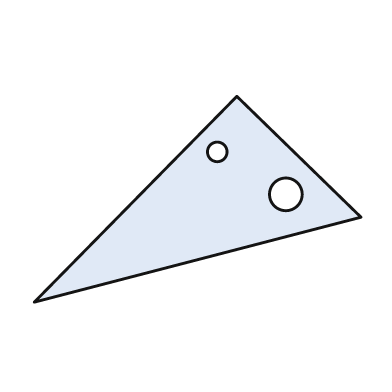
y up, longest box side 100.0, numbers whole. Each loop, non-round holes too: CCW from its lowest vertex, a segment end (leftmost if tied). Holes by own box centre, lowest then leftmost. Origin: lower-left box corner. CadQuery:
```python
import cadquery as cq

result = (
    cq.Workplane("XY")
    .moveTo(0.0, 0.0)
    .lineTo(100.0, 26.0)
    .lineTo(62.0, 63.0)
    .close()
    .moveTo(77.0, 33.0)
    .circle(5.0)
    .moveTo(56.0, 46.0)
    .circle(3.0)
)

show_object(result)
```